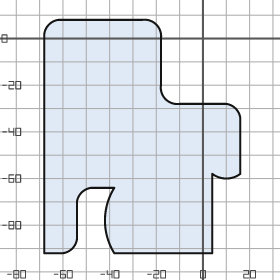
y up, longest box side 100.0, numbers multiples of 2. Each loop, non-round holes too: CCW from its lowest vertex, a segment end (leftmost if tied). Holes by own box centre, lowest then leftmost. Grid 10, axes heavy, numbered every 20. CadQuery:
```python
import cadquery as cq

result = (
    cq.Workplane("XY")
    .moveTo(-68.0, -92.0)
    .lineTo(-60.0, -92.0)
    .threePointArc((-56.0, -90.0), (-54.0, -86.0))
    .lineTo(-54.0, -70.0)
    .threePointArc((-52.0, -66.0), (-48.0, -64.0))
    .lineTo(-38.0, -64.0)
    .threePointArc((-42.0, -78.0), (-38.0, -92.0))
    .lineTo(4.0, -92.0)
    .lineTo(4.0, -58.0)
    .threePointArc((10.0, -60.0), (16.0, -58.0))
    .lineTo(16.0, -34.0)
    .threePointArc((14.0, -30.0), (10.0, -28.0))
    .lineTo(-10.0, -28.0)
    .threePointArc((-16.0, -26.0), (-18.0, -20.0))
    .lineTo(-18.0, 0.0)
    .threePointArc((-20.0, 6.0), (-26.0, 8.0))
    .lineTo(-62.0, 8.0)
    .threePointArc((-66.0, 6.0), (-68.0, 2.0))
    .close()
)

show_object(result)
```